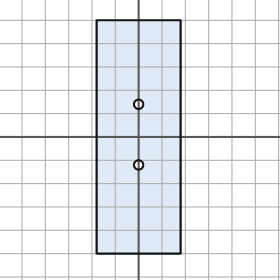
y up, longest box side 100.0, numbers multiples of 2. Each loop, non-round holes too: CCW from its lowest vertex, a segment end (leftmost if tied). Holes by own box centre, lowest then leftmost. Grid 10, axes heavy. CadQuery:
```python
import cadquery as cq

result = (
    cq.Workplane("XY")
    .moveTo(-18.0, -50.0)
    .lineTo(18.0, -50.0)
    .lineTo(18.0, 50.0)
    .lineTo(-18.0, 50.0)
    .close()
    .moveTo(0.0, -12.0)
    .circle(2.0)
    .moveTo(0.0, 14.0)
    .circle(2.0)
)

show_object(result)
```